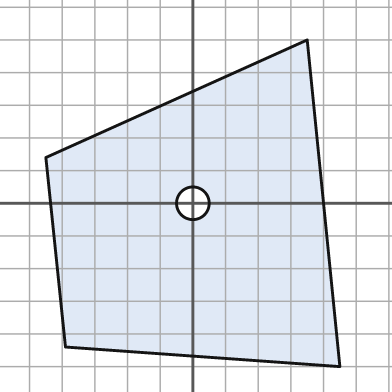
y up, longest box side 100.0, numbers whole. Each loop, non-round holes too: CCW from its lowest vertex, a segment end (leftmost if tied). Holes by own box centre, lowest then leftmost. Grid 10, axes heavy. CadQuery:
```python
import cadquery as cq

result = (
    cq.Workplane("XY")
    .moveTo(45.0, -50.0)
    .lineTo(35.0, 50.0)
    .lineTo(-45.0, 14.0)
    .lineTo(-39.0, -44.0)
    .close()
    .moveTo(0.0, 0.0)
    .circle(5.0)
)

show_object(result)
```